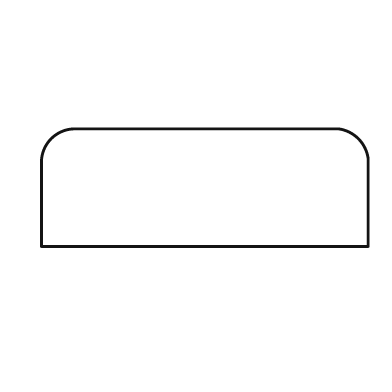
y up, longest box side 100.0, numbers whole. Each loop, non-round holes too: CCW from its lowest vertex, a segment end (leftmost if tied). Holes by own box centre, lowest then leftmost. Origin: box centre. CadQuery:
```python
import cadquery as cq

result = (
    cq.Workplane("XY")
    .moveTo(-50.0, -18.0)
    .lineTo(50.0, -18.0)
    .lineTo(50.0, 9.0)
    .threePointArc((47.0, 15.0), (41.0, 18.0))
    .lineTo(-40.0, 18.0)
    .threePointArc((-47.0, 15.0), (-50.0, 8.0))
    .close()
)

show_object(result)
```